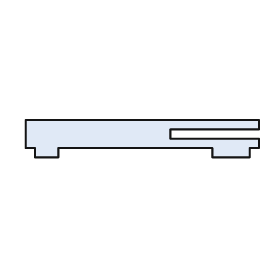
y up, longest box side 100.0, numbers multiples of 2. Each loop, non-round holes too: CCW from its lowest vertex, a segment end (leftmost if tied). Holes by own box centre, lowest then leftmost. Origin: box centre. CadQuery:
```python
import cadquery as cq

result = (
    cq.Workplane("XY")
    .moveTo(-46.0, -8.0)
    .lineTo(-36.0, -8.0)
    .lineTo(-36.0, -4.0)
    .lineTo(30.0, -4.0)
    .lineTo(30.0, -8.0)
    .lineTo(46.0, -8.0)
    .lineTo(46.0, -4.0)
    .lineTo(50.0, -4.0)
    .lineTo(50.0, 0.0)
    .lineTo(12.0, 0.0)
    .lineTo(12.0, 4.0)
    .lineTo(50.0, 4.0)
    .lineTo(50.0, 8.0)
    .lineTo(-50.0, 8.0)
    .lineTo(-50.0, -4.0)
    .lineTo(-46.0, -4.0)
    .close()
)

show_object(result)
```